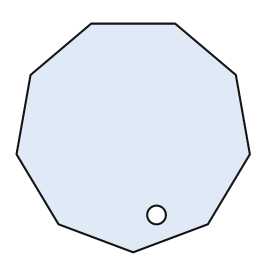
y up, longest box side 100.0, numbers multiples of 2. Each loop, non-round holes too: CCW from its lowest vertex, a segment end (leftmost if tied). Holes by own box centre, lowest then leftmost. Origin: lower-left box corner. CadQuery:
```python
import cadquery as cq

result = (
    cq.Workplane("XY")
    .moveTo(50.0, 0.0)
    .lineTo(82.0, 12.0)
    .lineTo(100.0, 42.0)
    .lineTo(94.0, 76.0)
    .lineTo(68.0, 98.0)
    .lineTo(32.0, 98.0)
    .lineTo(6.0, 76.0)
    .lineTo(0.0, 42.0)
    .lineTo(18.0, 12.0)
    .close()
    .moveTo(60.0, 16.0)
    .circle(4.0)
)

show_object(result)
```